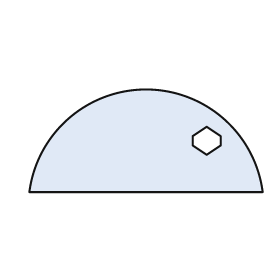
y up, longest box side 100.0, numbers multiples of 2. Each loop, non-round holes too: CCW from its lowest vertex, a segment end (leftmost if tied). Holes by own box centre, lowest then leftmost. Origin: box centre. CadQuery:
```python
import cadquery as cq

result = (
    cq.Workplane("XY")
    .moveTo(-50.0, -22.0)
    .lineTo(50.0, -22.0)
    .threePointArc((0.0, 22.0), (-50.0, -22.0))
    .close()
    .moveTo(26.0, -6.0)
    .lineTo(32.0, -2.0)
    .lineTo(32.0, 2.0)
    .lineTo(26.0, 6.0)
    .lineTo(20.0, 2.0)
    .lineTo(20.0, -2.0)
    .close()
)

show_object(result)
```